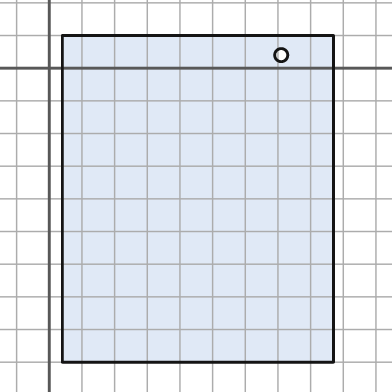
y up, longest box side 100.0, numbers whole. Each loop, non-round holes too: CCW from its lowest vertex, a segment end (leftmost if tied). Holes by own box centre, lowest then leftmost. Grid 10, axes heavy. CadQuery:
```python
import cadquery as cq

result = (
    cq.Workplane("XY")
    .moveTo(4.0, -90.0)
    .lineTo(87.0, -90.0)
    .lineTo(87.0, 10.0)
    .lineTo(4.0, 10.0)
    .close()
    .moveTo(71.0, 4.0)
    .circle(2.0)
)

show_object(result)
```